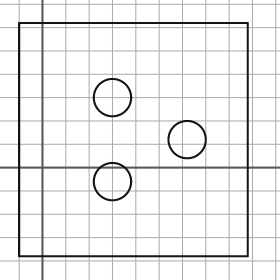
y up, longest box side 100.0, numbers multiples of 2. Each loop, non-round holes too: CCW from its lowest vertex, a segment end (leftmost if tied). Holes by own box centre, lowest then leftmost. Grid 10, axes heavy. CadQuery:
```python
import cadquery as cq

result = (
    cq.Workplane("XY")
    .moveTo(-10.0, -38.0)
    .lineTo(88.0, -38.0)
    .lineTo(88.0, 62.0)
    .lineTo(-10.0, 62.0)
    .close()
    .moveTo(30.0, -6.0)
    .circle(8.0)
    .moveTo(62.0, 12.0)
    .circle(8.0)
    .moveTo(30.0, 30.0)
    .circle(8.0)
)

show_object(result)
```